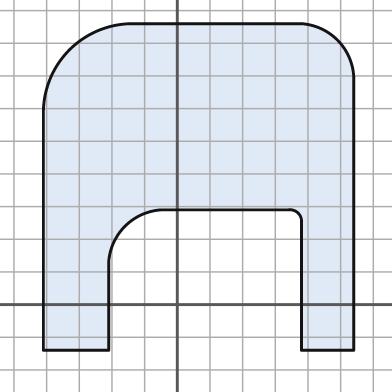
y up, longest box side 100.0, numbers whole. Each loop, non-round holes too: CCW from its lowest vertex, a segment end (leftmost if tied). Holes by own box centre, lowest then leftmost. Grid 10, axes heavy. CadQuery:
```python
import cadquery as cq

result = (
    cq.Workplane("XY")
    .moveTo(-41.0, -14.0)
    .lineTo(-21.0, -14.0)
    .lineTo(-21.0, 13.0)
    .threePointArc((-16.0, 24.0), (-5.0, 29.0))
    .lineTo(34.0, 29.0)
    .threePointArc((37.0, 28.0), (38.0, 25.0))
    .lineTo(38.0, -14.0)
    .lineTo(54.0, -14.0)
    .lineTo(54.0, 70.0)
    .threePointArc((49.0, 81.0), (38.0, 86.0))
    .lineTo(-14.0, 86.0)
    .threePointArc((-33.0, 78.0), (-41.0, 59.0))
    .close()
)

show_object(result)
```